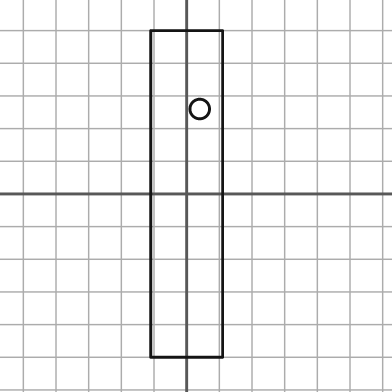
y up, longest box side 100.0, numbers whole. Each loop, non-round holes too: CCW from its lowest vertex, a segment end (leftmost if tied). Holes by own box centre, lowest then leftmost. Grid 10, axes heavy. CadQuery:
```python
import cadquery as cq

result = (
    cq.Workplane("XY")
    .moveTo(-11.0, -50.0)
    .lineTo(11.0, -50.0)
    .lineTo(11.0, 50.0)
    .lineTo(-11.0, 50.0)
    .close()
    .moveTo(4.0, 26.0)
    .circle(3.0)
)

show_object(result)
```